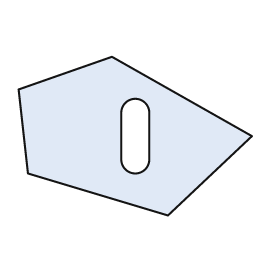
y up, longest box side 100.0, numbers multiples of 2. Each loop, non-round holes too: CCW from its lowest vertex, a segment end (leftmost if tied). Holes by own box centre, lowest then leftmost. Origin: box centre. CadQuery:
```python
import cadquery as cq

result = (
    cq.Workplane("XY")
    .moveTo(14.0, -34.0)
    .lineTo(50.0, 0.0)
    .lineTo(-10.0, 34.0)
    .lineTo(-50.0, 20.0)
    .lineTo(-46.0, -16.0)
    .close()
    .moveTo(-6.0, -10.0)
    .threePointArc((0.0, -16.0), (6.0, -10.0))
    .lineTo(6.0, 10.0)
    .threePointArc((0.0, 16.0), (-6.0, 10.0))
    .close()
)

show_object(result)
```